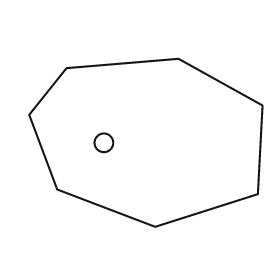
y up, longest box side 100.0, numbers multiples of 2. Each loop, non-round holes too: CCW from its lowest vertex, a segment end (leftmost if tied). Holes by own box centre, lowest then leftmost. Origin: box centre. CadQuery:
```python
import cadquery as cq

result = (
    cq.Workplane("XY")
    .moveTo(4.0, -36.0)
    .lineTo(48.0, -22.0)
    .lineTo(50.0, 16.0)
    .lineTo(14.0, 36.0)
    .lineTo(-34.0, 32.0)
    .lineTo(-50.0, 12.0)
    .lineTo(-38.0, -20.0)
    .close()
    .moveTo(-18.0, 0.0)
    .circle(4.0)
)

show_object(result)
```